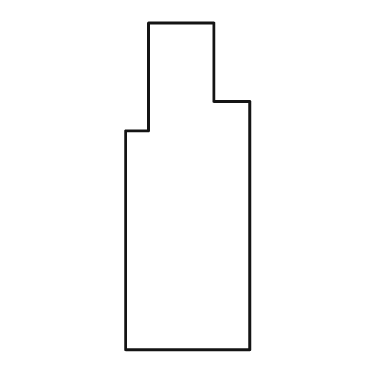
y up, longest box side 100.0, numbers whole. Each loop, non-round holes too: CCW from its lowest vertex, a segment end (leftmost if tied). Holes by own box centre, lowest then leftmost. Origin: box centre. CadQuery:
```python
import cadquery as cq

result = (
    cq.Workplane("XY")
    .moveTo(-19.0, -50.0)
    .lineTo(19.0, -50.0)
    .lineTo(19.0, 26.0)
    .lineTo(8.0, 26.0)
    .lineTo(8.0, 50.0)
    .lineTo(-12.0, 50.0)
    .lineTo(-12.0, 17.0)
    .lineTo(-19.0, 17.0)
    .close()
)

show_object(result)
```